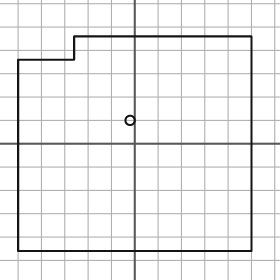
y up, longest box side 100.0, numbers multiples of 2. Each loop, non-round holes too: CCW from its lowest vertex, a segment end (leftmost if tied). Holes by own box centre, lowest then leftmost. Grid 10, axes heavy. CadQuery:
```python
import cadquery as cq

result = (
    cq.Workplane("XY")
    .moveTo(-50.0, -46.0)
    .lineTo(50.0, -46.0)
    .lineTo(50.0, 46.0)
    .lineTo(-26.0, 46.0)
    .lineTo(-26.0, 36.0)
    .lineTo(-50.0, 36.0)
    .close()
    .moveTo(-2.0, 10.0)
    .circle(2.0)
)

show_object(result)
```